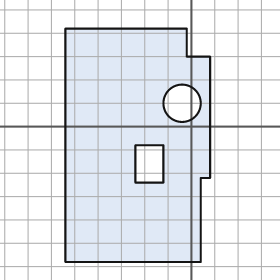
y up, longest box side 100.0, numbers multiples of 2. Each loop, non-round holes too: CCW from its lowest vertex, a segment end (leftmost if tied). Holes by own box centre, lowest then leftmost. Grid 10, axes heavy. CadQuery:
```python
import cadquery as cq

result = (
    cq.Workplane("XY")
    .moveTo(-54.0, -58.0)
    .lineTo(4.0, -58.0)
    .lineTo(4.0, -22.0)
    .lineTo(8.0, -22.0)
    .lineTo(8.0, 30.0)
    .lineTo(-2.0, 30.0)
    .lineTo(-2.0, 42.0)
    .lineTo(-54.0, 42.0)
    .close()
    .moveTo(-24.0, -24.0)
    .lineTo(-12.0, -24.0)
    .lineTo(-12.0, -8.0)
    .lineTo(-24.0, -8.0)
    .close()
    .moveTo(-4.0, 10.0)
    .circle(8.0)
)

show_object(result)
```